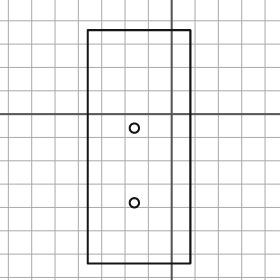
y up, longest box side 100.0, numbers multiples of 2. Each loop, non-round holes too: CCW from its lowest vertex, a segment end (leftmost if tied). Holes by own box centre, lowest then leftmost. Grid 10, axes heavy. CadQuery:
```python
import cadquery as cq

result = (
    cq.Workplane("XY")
    .moveTo(-36.0, -64.0)
    .lineTo(8.0, -64.0)
    .lineTo(8.0, 36.0)
    .lineTo(-36.0, 36.0)
    .close()
    .moveTo(-16.0, -38.0)
    .circle(2.0)
    .moveTo(-16.0, -6.0)
    .circle(2.0)
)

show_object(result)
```